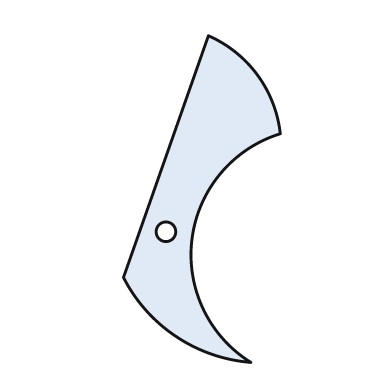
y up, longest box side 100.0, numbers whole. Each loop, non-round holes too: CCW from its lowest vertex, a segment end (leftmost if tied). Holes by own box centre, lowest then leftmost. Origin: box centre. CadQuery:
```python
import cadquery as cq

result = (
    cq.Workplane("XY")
    .moveTo(15.0, -50.0)
    .threePointArc((-3.0, -12.0), (24.0, 20.0))
    .threePointArc((17.0, 38.0), (2.0, 50.0))
    .lineTo(-24.0, -24.0)
    .threePointArc((-8.0, -42.0), (15.0, -50.0))
    .close()
    .moveTo(-11.0, -10.0)
    .circle(3.0)
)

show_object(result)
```